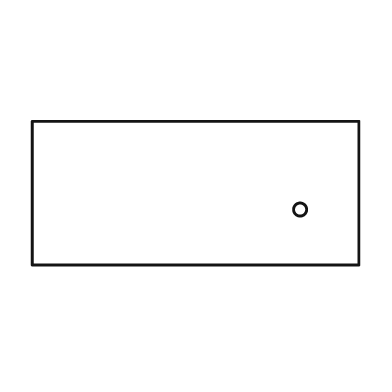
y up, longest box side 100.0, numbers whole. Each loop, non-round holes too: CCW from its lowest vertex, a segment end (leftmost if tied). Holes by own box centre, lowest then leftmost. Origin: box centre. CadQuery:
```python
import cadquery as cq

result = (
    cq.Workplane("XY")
    .moveTo(-50.0, -22.0)
    .lineTo(50.0, -22.0)
    .lineTo(50.0, 22.0)
    .lineTo(-50.0, 22.0)
    .close()
    .moveTo(32.0, -5.0)
    .circle(2.0)
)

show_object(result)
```